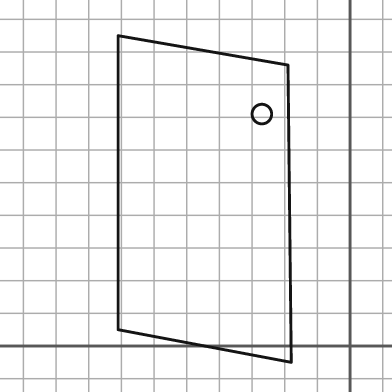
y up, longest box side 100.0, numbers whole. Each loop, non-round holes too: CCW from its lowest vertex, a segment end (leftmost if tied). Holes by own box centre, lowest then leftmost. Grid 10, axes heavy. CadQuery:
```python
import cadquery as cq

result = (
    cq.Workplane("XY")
    .moveTo(-18.0, -5.0)
    .lineTo(-19.0, 86.0)
    .lineTo(-71.0, 95.0)
    .lineTo(-71.0, 5.0)
    .close()
    .moveTo(-27.0, 71.0)
    .circle(3.0)
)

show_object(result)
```